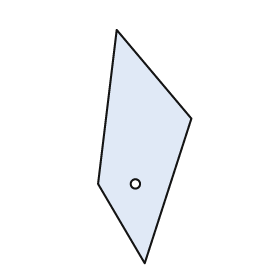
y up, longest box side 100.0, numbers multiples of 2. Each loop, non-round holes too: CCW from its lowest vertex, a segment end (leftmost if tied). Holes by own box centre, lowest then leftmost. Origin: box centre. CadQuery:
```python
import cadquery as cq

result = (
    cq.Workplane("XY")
    .moveTo(0.0, -50.0)
    .lineTo(20.0, 12.0)
    .lineTo(-12.0, 50.0)
    .lineTo(-20.0, -16.0)
    .close()
    .moveTo(-4.0, -16.0)
    .circle(2.0)
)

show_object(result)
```